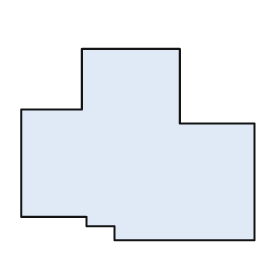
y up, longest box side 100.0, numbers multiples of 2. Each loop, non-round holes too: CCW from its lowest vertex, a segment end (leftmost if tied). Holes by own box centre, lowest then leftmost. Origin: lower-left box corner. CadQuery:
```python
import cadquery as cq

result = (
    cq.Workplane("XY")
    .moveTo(40.0, 0.0)
    .lineTo(100.0, 0.0)
    .lineTo(100.0, 50.0)
    .lineTo(68.0, 50.0)
    .lineTo(68.0, 82.0)
    .lineTo(26.0, 82.0)
    .lineTo(26.0, 56.0)
    .lineTo(0.0, 56.0)
    .lineTo(0.0, 10.0)
    .lineTo(28.0, 10.0)
    .lineTo(28.0, 6.0)
    .lineTo(40.0, 6.0)
    .close()
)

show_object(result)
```